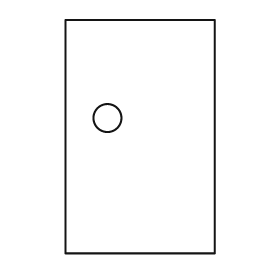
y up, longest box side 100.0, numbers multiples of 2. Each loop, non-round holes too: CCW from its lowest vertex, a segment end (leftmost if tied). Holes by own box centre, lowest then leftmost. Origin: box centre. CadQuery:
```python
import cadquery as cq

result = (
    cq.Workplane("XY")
    .moveTo(-32.0, -50.0)
    .lineTo(32.0, -50.0)
    .lineTo(32.0, 50.0)
    .lineTo(-32.0, 50.0)
    .close()
    .moveTo(-14.0, 8.0)
    .circle(6.0)
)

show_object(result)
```